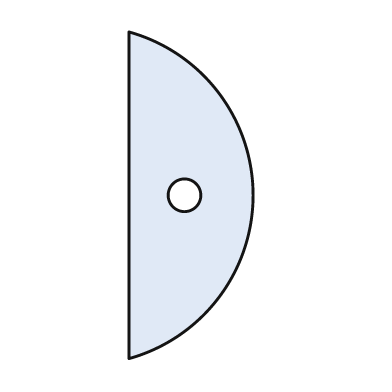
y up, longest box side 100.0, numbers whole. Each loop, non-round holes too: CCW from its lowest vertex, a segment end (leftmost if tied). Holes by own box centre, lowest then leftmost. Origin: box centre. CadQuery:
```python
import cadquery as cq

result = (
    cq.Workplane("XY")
    .moveTo(-19.0, -50.0)
    .threePointArc((19.0, 0.0), (-19.0, 50.0))
    .close()
    .moveTo(-2.0, 0.0)
    .circle(5.0)
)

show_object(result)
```